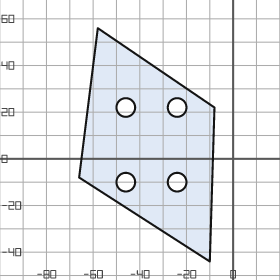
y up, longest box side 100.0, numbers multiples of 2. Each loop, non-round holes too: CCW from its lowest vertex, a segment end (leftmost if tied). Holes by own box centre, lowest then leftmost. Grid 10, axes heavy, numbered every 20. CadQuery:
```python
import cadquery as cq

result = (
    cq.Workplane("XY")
    .moveTo(-10.0, -44.0)
    .lineTo(-8.0, 22.0)
    .lineTo(-58.0, 56.0)
    .lineTo(-66.0, -8.0)
    .close()
    .moveTo(-46.0, -10.0)
    .circle(4.0)
    .moveTo(-24.0, -10.0)
    .circle(4.0)
    .moveTo(-46.0, 22.0)
    .circle(4.0)
    .moveTo(-24.0, 22.0)
    .circle(4.0)
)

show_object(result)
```